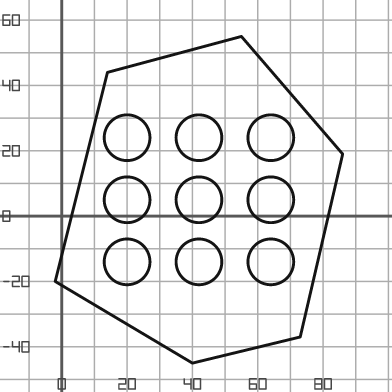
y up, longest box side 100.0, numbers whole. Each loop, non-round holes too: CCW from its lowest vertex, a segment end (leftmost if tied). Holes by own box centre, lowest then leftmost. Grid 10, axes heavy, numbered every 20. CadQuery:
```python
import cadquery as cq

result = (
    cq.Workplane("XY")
    .moveTo(40.0, -45.0)
    .lineTo(73.0, -37.0)
    .lineTo(86.0, 19.0)
    .lineTo(55.0, 55.0)
    .lineTo(14.0, 44.0)
    .lineTo(-2.0, -20.0)
    .close()
    .moveTo(20.0, -14.0)
    .circle(7.0)
    .moveTo(42.0, -14.0)
    .circle(7.0)
    .moveTo(64.0, -14.0)
    .circle(7.0)
    .moveTo(20.0, 5.0)
    .circle(7.0)
    .moveTo(42.0, 5.0)
    .circle(7.0)
    .moveTo(64.0, 5.0)
    .circle(7.0)
    .moveTo(20.0, 24.0)
    .circle(7.0)
    .moveTo(42.0, 24.0)
    .circle(7.0)
    .moveTo(64.0, 24.0)
    .circle(7.0)
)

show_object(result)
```